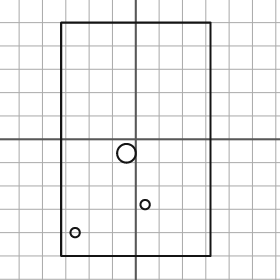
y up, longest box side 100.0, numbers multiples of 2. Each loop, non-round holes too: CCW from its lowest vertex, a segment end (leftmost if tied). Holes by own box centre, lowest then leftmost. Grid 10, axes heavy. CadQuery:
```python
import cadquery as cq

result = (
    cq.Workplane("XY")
    .moveTo(-32.0, -50.0)
    .lineTo(32.0, -50.0)
    .lineTo(32.0, 50.0)
    .lineTo(-32.0, 50.0)
    .close()
    .moveTo(-26.0, -40.0)
    .circle(2.0)
    .moveTo(4.0, -28.0)
    .circle(2.0)
    .moveTo(-4.0, -6.0)
    .circle(4.0)
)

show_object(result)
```